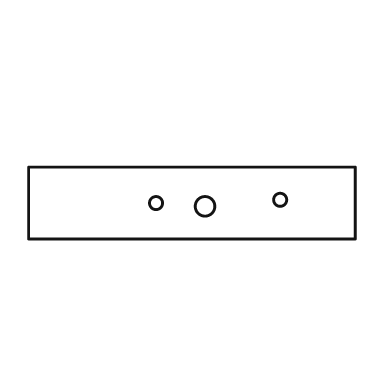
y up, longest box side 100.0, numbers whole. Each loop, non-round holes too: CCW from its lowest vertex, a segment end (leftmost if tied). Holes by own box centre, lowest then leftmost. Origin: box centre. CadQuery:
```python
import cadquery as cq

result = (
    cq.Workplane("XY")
    .moveTo(-50.0, -11.0)
    .lineTo(50.0, -11.0)
    .lineTo(50.0, 11.0)
    .lineTo(-50.0, 11.0)
    .close()
    .moveTo(4.0, -1.0)
    .circle(3.0)
    .moveTo(-11.0, 0.0)
    .circle(2.0)
    .moveTo(27.0, 1.0)
    .circle(2.0)
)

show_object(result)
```